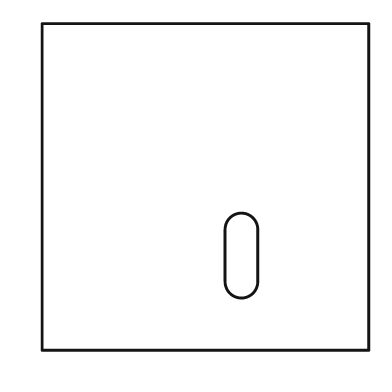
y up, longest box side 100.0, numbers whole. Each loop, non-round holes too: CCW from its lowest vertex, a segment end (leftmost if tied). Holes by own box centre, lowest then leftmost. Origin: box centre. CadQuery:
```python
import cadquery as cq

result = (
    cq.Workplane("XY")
    .moveTo(-50.0, -50.0)
    .lineTo(50.0, -50.0)
    .lineTo(50.0, 50.0)
    .lineTo(-50.0, 50.0)
    .close()
    .moveTo(6.0, -29.0)
    .threePointArc((11.0, -34.0), (16.0, -29.0))
    .lineTo(16.0, -13.0)
    .threePointArc((11.0, -8.0), (6.0, -13.0))
    .close()
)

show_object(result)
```